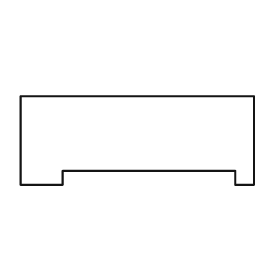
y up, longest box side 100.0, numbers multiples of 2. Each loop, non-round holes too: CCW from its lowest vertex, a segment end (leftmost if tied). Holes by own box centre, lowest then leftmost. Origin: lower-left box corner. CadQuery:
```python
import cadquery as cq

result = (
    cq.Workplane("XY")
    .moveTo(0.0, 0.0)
    .lineTo(18.0, 0.0)
    .lineTo(18.0, 6.0)
    .lineTo(92.0, 6.0)
    .lineTo(92.0, 0.0)
    .lineTo(100.0, 0.0)
    .lineTo(100.0, 38.0)
    .lineTo(0.0, 38.0)
    .close()
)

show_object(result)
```